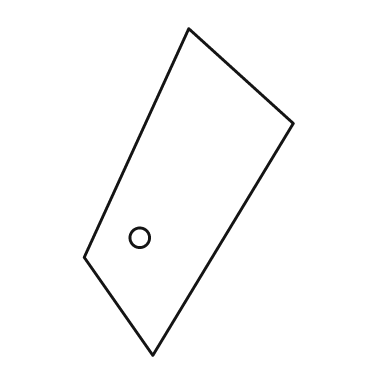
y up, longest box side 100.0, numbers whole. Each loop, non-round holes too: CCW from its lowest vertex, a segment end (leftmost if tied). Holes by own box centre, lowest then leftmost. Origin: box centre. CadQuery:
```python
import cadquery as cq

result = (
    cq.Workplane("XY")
    .moveTo(-11.0, -50.0)
    .lineTo(32.0, 21.0)
    .lineTo(0.0, 50.0)
    .lineTo(-32.0, -20.0)
    .close()
    .moveTo(-15.0, -14.0)
    .circle(3.0)
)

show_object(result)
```